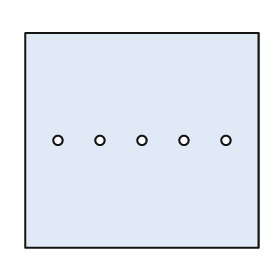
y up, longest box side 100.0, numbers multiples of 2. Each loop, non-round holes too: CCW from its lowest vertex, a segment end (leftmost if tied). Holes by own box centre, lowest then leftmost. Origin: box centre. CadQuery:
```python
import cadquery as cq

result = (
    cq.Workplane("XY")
    .moveTo(-50.0, -46.0)
    .lineTo(50.0, -46.0)
    .lineTo(50.0, 46.0)
    .lineTo(-50.0, 46.0)
    .close()
    .moveTo(-36.0, 0.0)
    .circle(2.0)
    .moveTo(-18.0, 0.0)
    .circle(2.0)
    .moveTo(0.0, 0.0)
    .circle(2.0)
    .moveTo(18.0, 0.0)
    .circle(2.0)
    .moveTo(36.0, 0.0)
    .circle(2.0)
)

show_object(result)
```